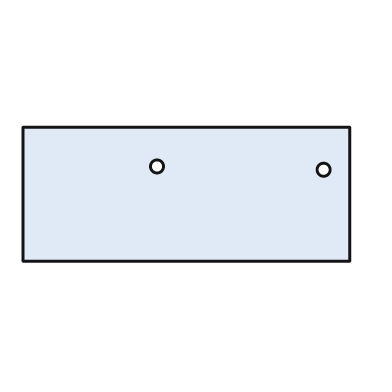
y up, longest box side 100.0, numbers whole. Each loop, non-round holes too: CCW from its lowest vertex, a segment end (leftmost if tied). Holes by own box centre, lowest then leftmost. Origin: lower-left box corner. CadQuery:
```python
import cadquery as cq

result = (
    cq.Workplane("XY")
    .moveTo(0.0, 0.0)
    .lineTo(100.0, 0.0)
    .lineTo(100.0, 41.0)
    .lineTo(0.0, 41.0)
    .close()
    .moveTo(92.0, 28.0)
    .circle(2.0)
    .moveTo(41.0, 29.0)
    .circle(2.0)
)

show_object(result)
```